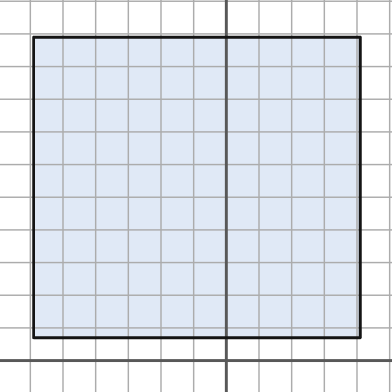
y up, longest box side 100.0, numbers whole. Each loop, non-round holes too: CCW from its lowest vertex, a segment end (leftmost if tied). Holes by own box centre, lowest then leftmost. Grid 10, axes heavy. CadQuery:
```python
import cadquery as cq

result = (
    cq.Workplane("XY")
    .moveTo(-59.0, 7.0)
    .lineTo(41.0, 7.0)
    .lineTo(41.0, 99.0)
    .lineTo(-59.0, 99.0)
    .close()
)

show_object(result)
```